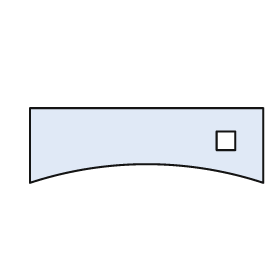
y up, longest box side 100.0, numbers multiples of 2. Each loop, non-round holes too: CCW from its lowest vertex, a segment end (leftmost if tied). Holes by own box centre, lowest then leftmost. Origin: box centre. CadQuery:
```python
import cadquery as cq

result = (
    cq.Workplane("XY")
    .moveTo(-50.0, -16.0)
    .threePointArc((0.0, -8.0), (50.0, -16.0))
    .lineTo(50.0, 16.0)
    .lineTo(-50.0, 16.0)
    .close()
    .moveTo(30.0, -2.0)
    .lineTo(38.0, -2.0)
    .lineTo(38.0, 6.0)
    .lineTo(30.0, 6.0)
    .close()
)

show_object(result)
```